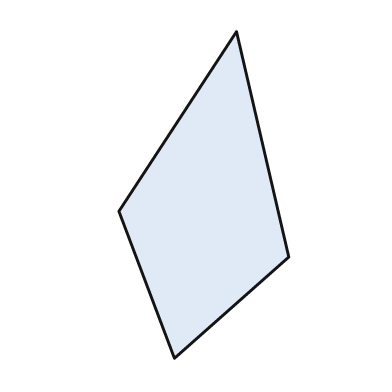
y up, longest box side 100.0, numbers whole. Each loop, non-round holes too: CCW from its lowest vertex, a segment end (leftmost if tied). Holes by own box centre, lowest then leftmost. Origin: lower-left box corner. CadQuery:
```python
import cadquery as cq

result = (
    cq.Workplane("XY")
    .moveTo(17.0, 0.0)
    .lineTo(52.0, 31.0)
    .lineTo(36.0, 100.0)
    .lineTo(0.0, 45.0)
    .close()
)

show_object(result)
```